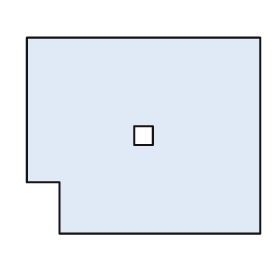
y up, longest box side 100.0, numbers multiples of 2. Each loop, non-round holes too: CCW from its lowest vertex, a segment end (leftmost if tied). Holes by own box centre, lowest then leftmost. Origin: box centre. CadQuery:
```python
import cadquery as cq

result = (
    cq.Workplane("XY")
    .moveTo(-36.0, -42.0)
    .lineTo(50.0, -42.0)
    .lineTo(50.0, 42.0)
    .lineTo(-50.0, 42.0)
    .lineTo(-50.0, -20.0)
    .lineTo(-36.0, -20.0)
    .close()
    .moveTo(-4.0, -4.0)
    .lineTo(4.0, -4.0)
    .lineTo(4.0, 4.0)
    .lineTo(-4.0, 4.0)
    .close()
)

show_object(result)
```